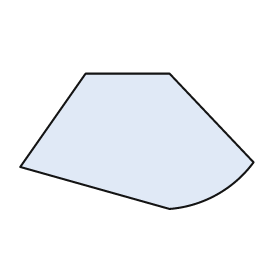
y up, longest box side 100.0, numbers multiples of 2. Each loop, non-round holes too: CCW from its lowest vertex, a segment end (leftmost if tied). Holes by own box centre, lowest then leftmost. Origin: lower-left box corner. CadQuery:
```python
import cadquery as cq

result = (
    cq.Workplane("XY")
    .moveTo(64.0, 0.0)
    .threePointArc((84.0, 6.0), (100.0, 20.0))
    .lineTo(64.0, 58.0)
    .lineTo(28.0, 58.0)
    .lineTo(0.0, 18.0)
    .close()
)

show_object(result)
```